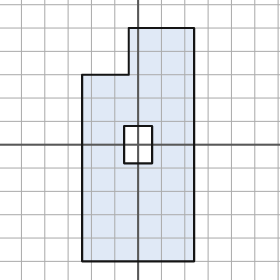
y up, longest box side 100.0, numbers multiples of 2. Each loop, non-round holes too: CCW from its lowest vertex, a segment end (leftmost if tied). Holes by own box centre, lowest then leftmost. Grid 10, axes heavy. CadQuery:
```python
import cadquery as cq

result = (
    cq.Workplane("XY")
    .moveTo(-24.0, -50.0)
    .lineTo(24.0, -50.0)
    .lineTo(24.0, 50.0)
    .lineTo(-4.0, 50.0)
    .lineTo(-4.0, 30.0)
    .lineTo(-24.0, 30.0)
    .close()
    .moveTo(-6.0, -8.0)
    .lineTo(6.0, -8.0)
    .lineTo(6.0, 8.0)
    .lineTo(-6.0, 8.0)
    .close()
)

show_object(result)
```